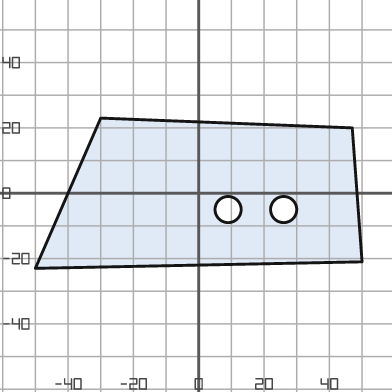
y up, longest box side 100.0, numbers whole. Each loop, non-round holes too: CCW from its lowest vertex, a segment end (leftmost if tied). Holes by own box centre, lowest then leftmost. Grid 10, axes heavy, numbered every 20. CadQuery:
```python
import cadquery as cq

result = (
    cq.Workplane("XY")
    .moveTo(-50.0, -23.0)
    .lineTo(50.0, -21.0)
    .lineTo(47.0, 20.0)
    .lineTo(-30.0, 23.0)
    .close()
    .moveTo(9.0, -5.0)
    .circle(4.0)
    .moveTo(26.0, -5.0)
    .circle(4.0)
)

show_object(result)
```